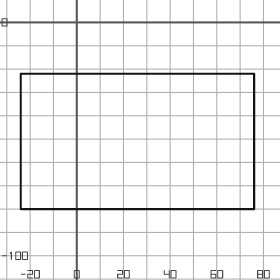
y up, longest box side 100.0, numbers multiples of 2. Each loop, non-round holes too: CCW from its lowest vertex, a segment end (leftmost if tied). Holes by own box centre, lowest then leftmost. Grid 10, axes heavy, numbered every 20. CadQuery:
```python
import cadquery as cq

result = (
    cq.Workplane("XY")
    .moveTo(-24.0, -80.0)
    .lineTo(76.0, -80.0)
    .lineTo(76.0, -22.0)
    .lineTo(-24.0, -22.0)
    .close()
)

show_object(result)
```